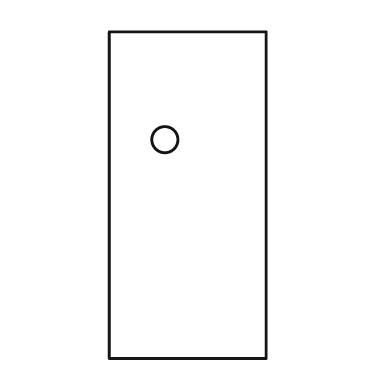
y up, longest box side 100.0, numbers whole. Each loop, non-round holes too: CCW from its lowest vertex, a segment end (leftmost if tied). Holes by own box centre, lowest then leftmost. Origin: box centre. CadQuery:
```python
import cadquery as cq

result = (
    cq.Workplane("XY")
    .moveTo(-24.0, -50.0)
    .lineTo(24.0, -50.0)
    .lineTo(24.0, 50.0)
    .lineTo(-24.0, 50.0)
    .close()
    .moveTo(-7.0, 17.0)
    .circle(4.0)
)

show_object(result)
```